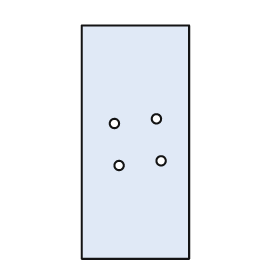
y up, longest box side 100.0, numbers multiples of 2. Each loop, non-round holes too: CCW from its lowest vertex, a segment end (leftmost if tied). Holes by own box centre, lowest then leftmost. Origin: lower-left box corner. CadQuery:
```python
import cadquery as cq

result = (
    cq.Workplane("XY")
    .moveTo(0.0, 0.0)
    .lineTo(46.0, 0.0)
    .lineTo(46.0, 100.0)
    .lineTo(0.0, 100.0)
    .close()
    .moveTo(16.0, 40.0)
    .circle(2.0)
    .moveTo(34.0, 42.0)
    .circle(2.0)
    .moveTo(14.0, 58.0)
    .circle(2.0)
    .moveTo(32.0, 60.0)
    .circle(2.0)
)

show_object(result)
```